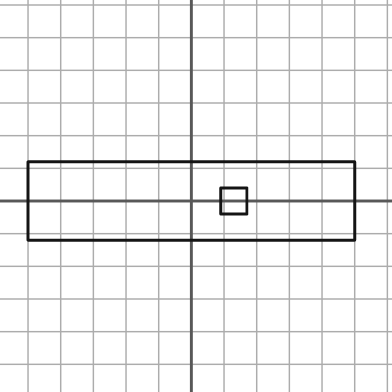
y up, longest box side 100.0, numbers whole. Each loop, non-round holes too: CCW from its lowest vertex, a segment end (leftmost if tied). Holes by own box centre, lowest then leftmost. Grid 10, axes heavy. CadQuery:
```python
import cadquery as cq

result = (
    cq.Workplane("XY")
    .moveTo(-50.0, -12.0)
    .lineTo(50.0, -12.0)
    .lineTo(50.0, 12.0)
    .lineTo(-50.0, 12.0)
    .close()
    .moveTo(9.0, -4.0)
    .lineTo(17.0, -4.0)
    .lineTo(17.0, 4.0)
    .lineTo(9.0, 4.0)
    .close()
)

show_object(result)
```